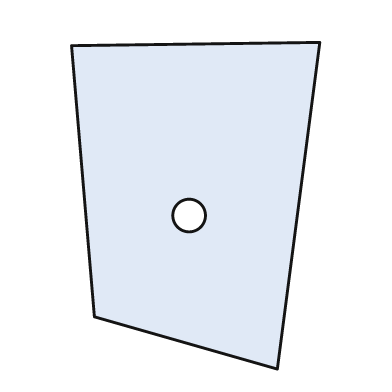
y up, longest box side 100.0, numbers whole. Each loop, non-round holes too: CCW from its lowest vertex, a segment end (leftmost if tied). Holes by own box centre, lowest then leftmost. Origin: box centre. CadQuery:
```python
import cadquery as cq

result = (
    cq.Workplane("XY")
    .moveTo(25.0, -50.0)
    .lineTo(38.0, 50.0)
    .lineTo(-38.0, 49.0)
    .lineTo(-31.0, -34.0)
    .close()
    .moveTo(-2.0, -3.0)
    .circle(5.0)
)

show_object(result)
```